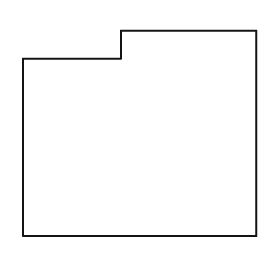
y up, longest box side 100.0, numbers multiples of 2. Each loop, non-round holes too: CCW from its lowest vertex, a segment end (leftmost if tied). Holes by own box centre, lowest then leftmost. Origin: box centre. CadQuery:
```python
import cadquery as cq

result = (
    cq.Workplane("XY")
    .moveTo(-50.0, -44.0)
    .lineTo(50.0, -44.0)
    .lineTo(50.0, 44.0)
    .lineTo(-8.0, 44.0)
    .lineTo(-8.0, 32.0)
    .lineTo(-50.0, 32.0)
    .close()
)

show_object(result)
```